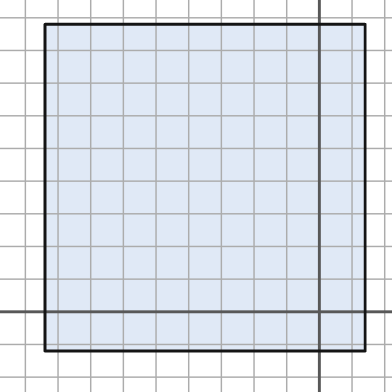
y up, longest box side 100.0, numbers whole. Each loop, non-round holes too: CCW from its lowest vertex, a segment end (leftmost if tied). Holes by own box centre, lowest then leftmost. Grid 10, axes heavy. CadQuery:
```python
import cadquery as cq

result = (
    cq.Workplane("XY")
    .moveTo(-84.0, -12.0)
    .lineTo(14.0, -12.0)
    .lineTo(14.0, 88.0)
    .lineTo(-84.0, 88.0)
    .close()
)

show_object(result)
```